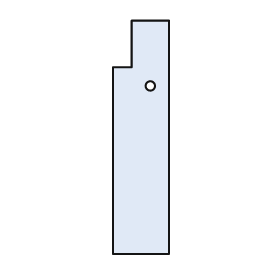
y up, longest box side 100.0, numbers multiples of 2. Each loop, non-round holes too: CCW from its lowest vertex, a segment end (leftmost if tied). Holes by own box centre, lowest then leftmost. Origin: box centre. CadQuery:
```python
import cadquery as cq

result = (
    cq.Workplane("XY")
    .moveTo(-12.0, -50.0)
    .lineTo(12.0, -50.0)
    .lineTo(12.0, 50.0)
    .lineTo(-4.0, 50.0)
    .lineTo(-4.0, 30.0)
    .lineTo(-12.0, 30.0)
    .close()
    .moveTo(4.0, 22.0)
    .circle(2.0)
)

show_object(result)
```